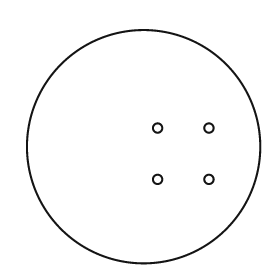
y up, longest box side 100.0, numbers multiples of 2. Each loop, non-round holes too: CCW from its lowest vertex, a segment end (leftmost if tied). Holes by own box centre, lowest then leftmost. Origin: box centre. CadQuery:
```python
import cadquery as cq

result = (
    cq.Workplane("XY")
    .moveTo(0.0, 0.0)
    .circle(50.0)
    .moveTo(6.0, -14.0)
    .circle(2.0)
    .moveTo(28.0, -14.0)
    .circle(2.0)
    .moveTo(6.0, 8.0)
    .circle(2.0)
    .moveTo(28.0, 8.0)
    .circle(2.0)
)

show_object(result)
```